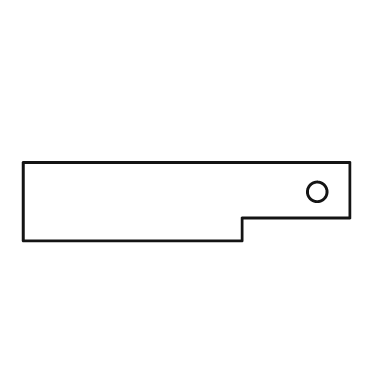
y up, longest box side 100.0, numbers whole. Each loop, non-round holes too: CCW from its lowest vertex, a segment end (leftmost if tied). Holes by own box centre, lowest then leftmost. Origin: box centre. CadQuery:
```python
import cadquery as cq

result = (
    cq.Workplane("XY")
    .moveTo(-50.0, -12.0)
    .lineTo(17.0, -12.0)
    .lineTo(17.0, -5.0)
    .lineTo(50.0, -5.0)
    .lineTo(50.0, 12.0)
    .lineTo(-50.0, 12.0)
    .close()
    .moveTo(40.0, 3.0)
    .circle(3.0)
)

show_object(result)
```